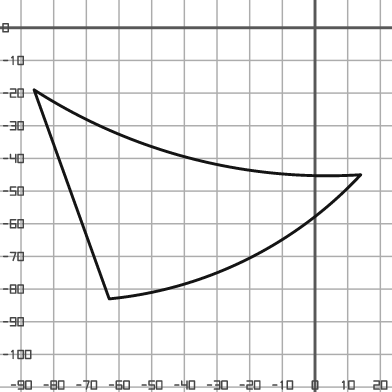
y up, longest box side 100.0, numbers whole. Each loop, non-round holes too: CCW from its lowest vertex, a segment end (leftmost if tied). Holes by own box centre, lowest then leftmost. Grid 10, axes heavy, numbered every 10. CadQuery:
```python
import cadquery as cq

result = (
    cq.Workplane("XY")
    .moveTo(-63.0, -83.0)
    .threePointArc((-21.0, -71.0), (14.0, -45.0))
    .threePointArc((-38.0, -40.0), (-86.0, -19.0))
    .close()
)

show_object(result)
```